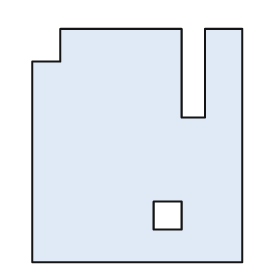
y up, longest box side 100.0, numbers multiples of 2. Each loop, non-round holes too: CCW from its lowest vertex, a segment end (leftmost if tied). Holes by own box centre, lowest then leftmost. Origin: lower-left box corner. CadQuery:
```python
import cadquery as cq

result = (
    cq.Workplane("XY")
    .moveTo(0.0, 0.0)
    .lineTo(90.0, 0.0)
    .lineTo(90.0, 100.0)
    .lineTo(74.0, 100.0)
    .lineTo(74.0, 62.0)
    .lineTo(64.0, 62.0)
    .lineTo(64.0, 100.0)
    .lineTo(12.0, 100.0)
    .lineTo(12.0, 86.0)
    .lineTo(0.0, 86.0)
    .close()
    .moveTo(52.0, 14.0)
    .lineTo(64.0, 14.0)
    .lineTo(64.0, 26.0)
    .lineTo(52.0, 26.0)
    .close()
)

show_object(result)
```